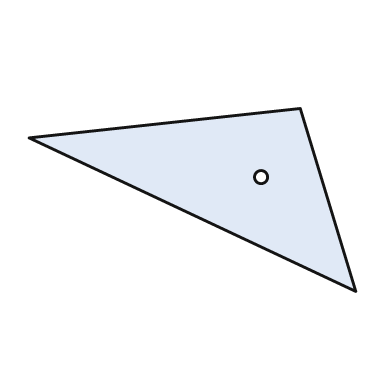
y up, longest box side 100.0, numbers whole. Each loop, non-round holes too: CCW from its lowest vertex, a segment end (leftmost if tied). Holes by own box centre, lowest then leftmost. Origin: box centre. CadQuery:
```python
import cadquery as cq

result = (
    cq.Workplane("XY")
    .moveTo(50.0, -28.0)
    .lineTo(33.0, 28.0)
    .lineTo(-50.0, 19.0)
    .close()
    .moveTo(21.0, 7.0)
    .circle(2.0)
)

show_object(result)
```